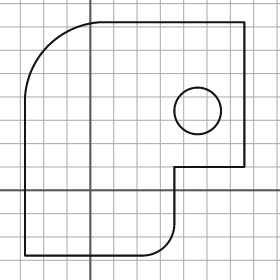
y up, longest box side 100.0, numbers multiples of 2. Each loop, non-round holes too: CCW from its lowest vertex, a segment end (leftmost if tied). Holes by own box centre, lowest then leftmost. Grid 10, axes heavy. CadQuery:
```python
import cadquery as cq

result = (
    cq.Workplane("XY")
    .moveTo(-28.0, -28.0)
    .lineTo(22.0, -28.0)
    .threePointArc((32.0, -24.0), (36.0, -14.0))
    .lineTo(36.0, 10.0)
    .lineTo(66.0, 10.0)
    .lineTo(66.0, 72.0)
    .lineTo(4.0, 72.0)
    .threePointArc((-18.0, 62.0), (-28.0, 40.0))
    .close()
    .moveTo(46.0, 34.0)
    .circle(10.0)
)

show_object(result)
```